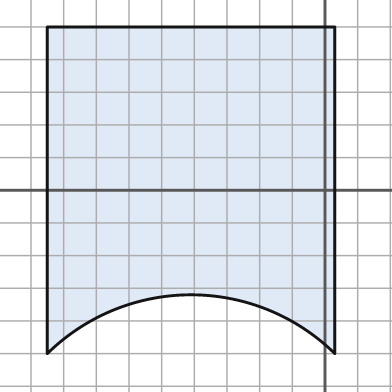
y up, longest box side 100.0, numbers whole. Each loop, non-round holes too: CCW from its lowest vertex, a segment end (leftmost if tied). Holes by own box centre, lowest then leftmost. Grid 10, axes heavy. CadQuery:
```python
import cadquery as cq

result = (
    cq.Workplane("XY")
    .moveTo(-85.0, -50.0)
    .threePointArc((-41.0, -32.0), (3.0, -50.0))
    .lineTo(3.0, 50.0)
    .lineTo(-85.0, 50.0)
    .close()
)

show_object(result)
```